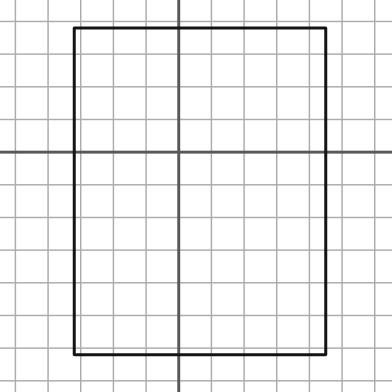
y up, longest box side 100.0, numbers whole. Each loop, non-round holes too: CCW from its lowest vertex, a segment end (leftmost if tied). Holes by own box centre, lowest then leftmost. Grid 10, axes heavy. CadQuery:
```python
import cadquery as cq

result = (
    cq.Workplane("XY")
    .moveTo(-32.0, -62.0)
    .lineTo(45.0, -62.0)
    .lineTo(45.0, 38.0)
    .lineTo(-32.0, 38.0)
    .close()
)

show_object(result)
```